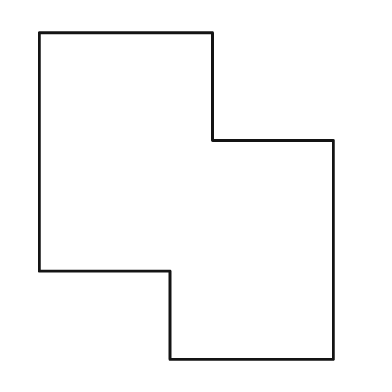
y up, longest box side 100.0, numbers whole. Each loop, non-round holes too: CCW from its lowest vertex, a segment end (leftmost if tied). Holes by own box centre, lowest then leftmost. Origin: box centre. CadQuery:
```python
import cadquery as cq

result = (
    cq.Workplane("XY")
    .moveTo(-5.0, -50.0)
    .lineTo(45.0, -50.0)
    .lineTo(45.0, 17.0)
    .lineTo(8.0, 17.0)
    .lineTo(8.0, 50.0)
    .lineTo(-45.0, 50.0)
    .lineTo(-45.0, -23.0)
    .lineTo(-5.0, -23.0)
    .close()
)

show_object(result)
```